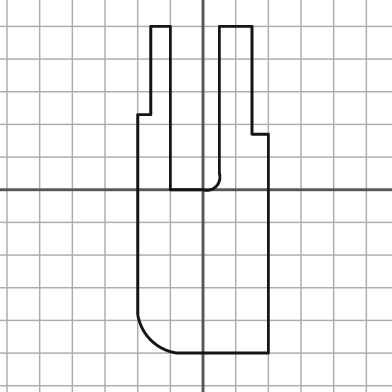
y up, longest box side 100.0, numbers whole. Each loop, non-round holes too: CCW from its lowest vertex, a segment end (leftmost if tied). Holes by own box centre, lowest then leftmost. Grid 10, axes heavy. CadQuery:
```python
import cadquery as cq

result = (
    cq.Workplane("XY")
    .moveTo(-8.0, -50.0)
    .lineTo(20.0, -50.0)
    .lineTo(20.0, 17.0)
    .lineTo(15.0, 17.0)
    .lineTo(15.0, 50.0)
    .lineTo(5.0, 50.0)
    .lineTo(5.0, 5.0)
    .threePointArc((4.0, 1.0), (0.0, 0.0))
    .lineTo(-10.0, 0.0)
    .lineTo(-10.0, 50.0)
    .lineTo(-16.0, 50.0)
    .lineTo(-16.0, 23.0)
    .lineTo(-20.0, 23.0)
    .lineTo(-20.0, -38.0)
    .threePointArc((-16.0, -46.0), (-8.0, -50.0))
    .close()
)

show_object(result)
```